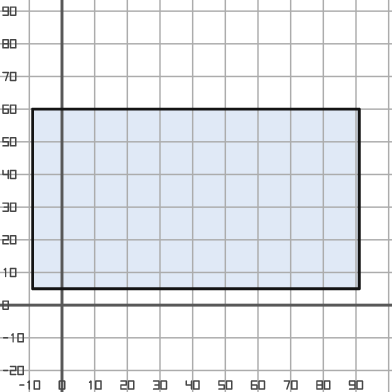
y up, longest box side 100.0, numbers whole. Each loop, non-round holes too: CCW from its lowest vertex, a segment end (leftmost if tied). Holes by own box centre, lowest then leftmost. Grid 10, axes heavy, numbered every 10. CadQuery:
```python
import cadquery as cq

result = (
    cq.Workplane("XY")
    .moveTo(-9.0, 5.0)
    .lineTo(91.0, 5.0)
    .lineTo(91.0, 60.0)
    .lineTo(-9.0, 60.0)
    .close()
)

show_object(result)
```